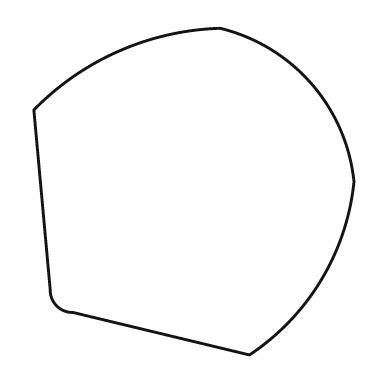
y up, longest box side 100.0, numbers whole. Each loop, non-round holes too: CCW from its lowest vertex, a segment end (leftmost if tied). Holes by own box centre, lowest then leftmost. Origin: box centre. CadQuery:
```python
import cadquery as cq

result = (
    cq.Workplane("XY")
    .moveTo(17.0, -50.0)
    .threePointArc((39.0, -27.0), (49.0, 3.0))
    .threePointArc((36.0, 33.0), (8.0, 50.0))
    .threePointArc((-23.0, 43.0), (-49.0, 25.0))
    .lineTo(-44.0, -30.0)
    .threePointArc((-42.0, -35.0), (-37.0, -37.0))
    .close()
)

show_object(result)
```